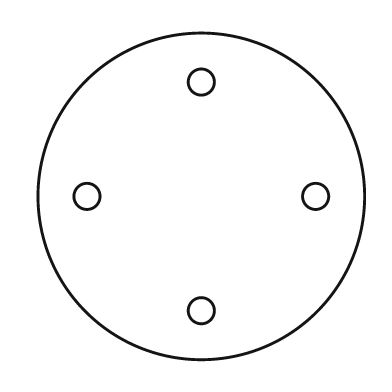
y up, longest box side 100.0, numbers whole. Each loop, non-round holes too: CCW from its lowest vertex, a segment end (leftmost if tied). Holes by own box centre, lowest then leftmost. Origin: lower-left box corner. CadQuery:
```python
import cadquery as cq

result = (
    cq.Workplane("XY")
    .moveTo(50.0, 50.0)
    .circle(50.0)
    .moveTo(50.0, 15.0)
    .circle(4.0)
    .moveTo(15.0, 50.0)
    .circle(4.0)
    .moveTo(85.0, 50.0)
    .circle(4.0)
    .moveTo(50.0, 85.0)
    .circle(4.0)
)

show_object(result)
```